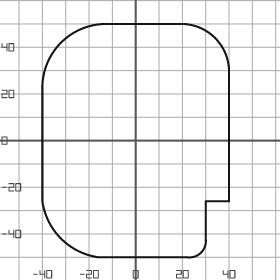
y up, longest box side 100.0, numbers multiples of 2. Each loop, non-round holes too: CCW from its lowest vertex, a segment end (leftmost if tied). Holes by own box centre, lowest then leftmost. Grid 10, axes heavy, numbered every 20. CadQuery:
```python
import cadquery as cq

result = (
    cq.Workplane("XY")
    .moveTo(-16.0, -50.0)
    .lineTo(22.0, -50.0)
    .threePointArc((28.0, -48.0), (30.0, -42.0))
    .lineTo(30.0, -26.0)
    .lineTo(40.0, -26.0)
    .lineTo(40.0, 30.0)
    .threePointArc((34.0, 44.0), (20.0, 50.0))
    .lineTo(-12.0, 50.0)
    .threePointArc((-32.0, 42.0), (-40.0, 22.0))
    .lineTo(-40.0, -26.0)
    .threePointArc((-32.0, -42.0), (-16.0, -50.0))
    .close()
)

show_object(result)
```